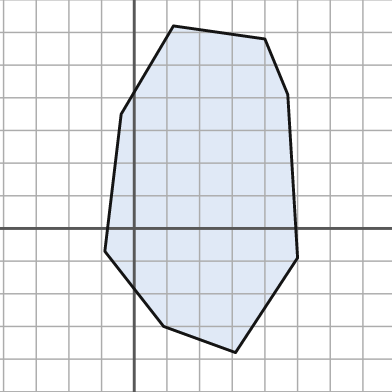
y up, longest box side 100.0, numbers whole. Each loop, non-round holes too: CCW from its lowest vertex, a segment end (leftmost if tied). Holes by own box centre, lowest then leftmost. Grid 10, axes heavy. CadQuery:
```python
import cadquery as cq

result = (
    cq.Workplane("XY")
    .moveTo(31.0, -38.0)
    .lineTo(50.0, -9.0)
    .lineTo(47.0, 41.0)
    .lineTo(40.0, 58.0)
    .lineTo(12.0, 62.0)
    .lineTo(-4.0, 35.0)
    .lineTo(-9.0, -7.0)
    .lineTo(9.0, -30.0)
    .close()
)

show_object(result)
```